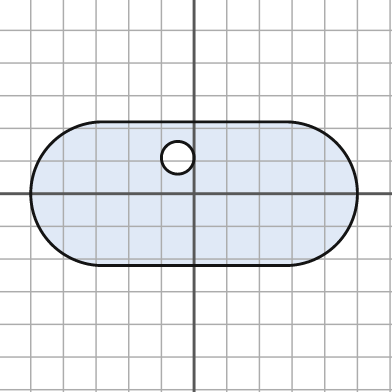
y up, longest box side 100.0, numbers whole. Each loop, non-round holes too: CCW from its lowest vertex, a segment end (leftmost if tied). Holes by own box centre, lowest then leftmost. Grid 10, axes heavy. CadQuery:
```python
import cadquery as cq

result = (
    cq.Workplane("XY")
    .moveTo(-28.0, -22.0)
    .lineTo(28.0, -22.0)
    .threePointArc((50.0, 0.0), (28.0, 22.0))
    .lineTo(-28.0, 22.0)
    .threePointArc((-50.0, 0.0), (-28.0, -22.0))
    .close()
    .moveTo(-5.0, 11.0)
    .circle(5.0)
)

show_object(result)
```